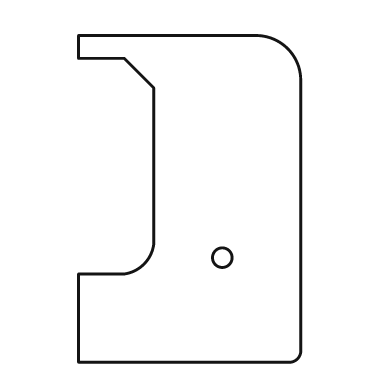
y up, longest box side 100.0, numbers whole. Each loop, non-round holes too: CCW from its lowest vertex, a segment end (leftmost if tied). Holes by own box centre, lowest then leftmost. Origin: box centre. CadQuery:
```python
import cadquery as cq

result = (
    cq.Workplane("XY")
    .moveTo(-34.0, -50.0)
    .lineTo(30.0, -50.0)
    .threePointArc((33.0, -49.0), (34.0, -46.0))
    .lineTo(34.0, 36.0)
    .threePointArc((30.0, 46.0), (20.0, 50.0))
    .lineTo(-34.0, 50.0)
    .lineTo(-34.0, 43.0)
    .lineTo(-20.0, 43.0)
    .lineTo(-11.0, 34.0)
    .lineTo(-11.0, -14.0)
    .threePointArc((-14.0, -20.0), (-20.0, -23.0))
    .lineTo(-34.0, -23.0)
    .close()
    .moveTo(10.0, -18.0)
    .circle(3.0)
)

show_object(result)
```